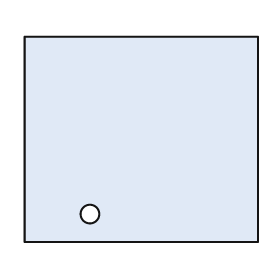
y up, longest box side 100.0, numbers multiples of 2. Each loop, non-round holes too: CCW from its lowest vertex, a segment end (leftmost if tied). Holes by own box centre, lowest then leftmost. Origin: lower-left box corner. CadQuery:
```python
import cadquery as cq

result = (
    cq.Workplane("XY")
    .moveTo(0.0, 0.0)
    .lineTo(100.0, 0.0)
    .lineTo(100.0, 88.0)
    .lineTo(0.0, 88.0)
    .close()
    .moveTo(28.0, 12.0)
    .circle(4.0)
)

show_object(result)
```